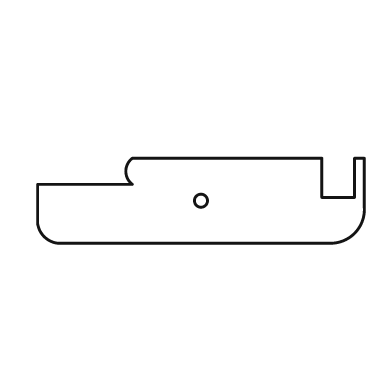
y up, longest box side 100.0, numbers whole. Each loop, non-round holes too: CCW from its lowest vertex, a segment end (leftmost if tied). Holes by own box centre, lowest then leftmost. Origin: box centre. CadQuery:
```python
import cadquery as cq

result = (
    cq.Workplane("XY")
    .moveTo(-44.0, -13.0)
    .lineTo(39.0, -13.0)
    .threePointArc((47.0, -10.0), (50.0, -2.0))
    .lineTo(50.0, 13.0)
    .lineTo(47.0, 13.0)
    .lineTo(47.0, 1.0)
    .lineTo(37.0, 1.0)
    .lineTo(37.0, 13.0)
    .lineTo(-21.0, 13.0)
    .threePointArc((-23.0, 9.0), (-21.0, 5.0))
    .lineTo(-50.0, 5.0)
    .lineTo(-50.0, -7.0)
    .threePointArc((-48.0, -11.0), (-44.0, -13.0))
    .close()
    .moveTo(0.0, 0.0)
    .circle(2.0)
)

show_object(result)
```